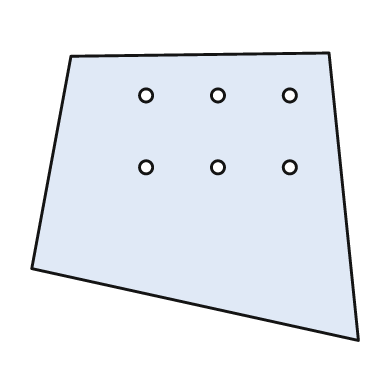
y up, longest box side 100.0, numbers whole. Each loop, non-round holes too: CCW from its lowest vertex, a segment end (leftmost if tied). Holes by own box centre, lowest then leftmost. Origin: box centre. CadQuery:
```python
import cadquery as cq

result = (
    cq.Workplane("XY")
    .moveTo(50.0, -44.0)
    .lineTo(41.0, 44.0)
    .lineTo(-38.0, 43.0)
    .lineTo(-50.0, -22.0)
    .close()
    .moveTo(-15.0, 9.0)
    .circle(2.0)
    .moveTo(7.0, 9.0)
    .circle(2.0)
    .moveTo(29.0, 9.0)
    .circle(2.0)
    .moveTo(-15.0, 31.0)
    .circle(2.0)
    .moveTo(7.0, 31.0)
    .circle(2.0)
    .moveTo(29.0, 31.0)
    .circle(2.0)
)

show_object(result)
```